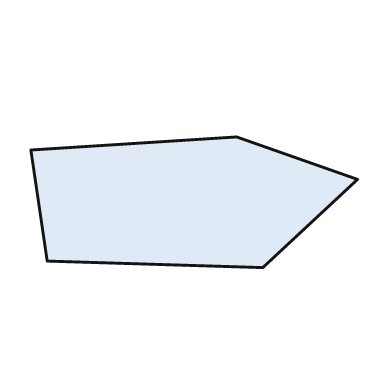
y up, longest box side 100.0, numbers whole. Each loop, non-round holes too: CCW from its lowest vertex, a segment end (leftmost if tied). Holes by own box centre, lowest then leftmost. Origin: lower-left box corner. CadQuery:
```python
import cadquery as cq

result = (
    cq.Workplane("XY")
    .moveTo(71.0, 0.0)
    .lineTo(100.0, 27.0)
    .lineTo(63.0, 40.0)
    .lineTo(0.0, 36.0)
    .lineTo(5.0, 2.0)
    .close()
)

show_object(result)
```